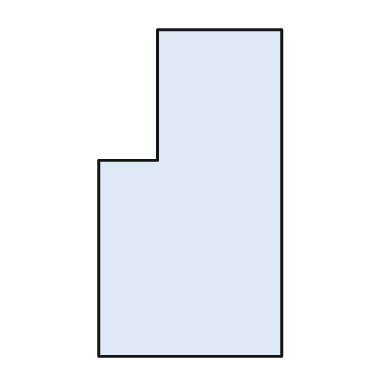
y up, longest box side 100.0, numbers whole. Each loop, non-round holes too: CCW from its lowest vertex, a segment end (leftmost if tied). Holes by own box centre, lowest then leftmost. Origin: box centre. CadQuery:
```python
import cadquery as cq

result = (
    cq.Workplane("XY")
    .moveTo(-28.0, -50.0)
    .lineTo(28.0, -50.0)
    .lineTo(28.0, 50.0)
    .lineTo(-10.0, 50.0)
    .lineTo(-10.0, 10.0)
    .lineTo(-28.0, 10.0)
    .close()
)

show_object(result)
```